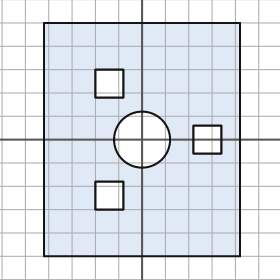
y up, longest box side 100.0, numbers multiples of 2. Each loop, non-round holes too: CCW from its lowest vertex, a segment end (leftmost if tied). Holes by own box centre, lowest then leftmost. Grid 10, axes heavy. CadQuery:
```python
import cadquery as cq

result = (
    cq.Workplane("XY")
    .moveTo(-42.0, -50.0)
    .lineTo(42.0, -50.0)
    .lineTo(42.0, 50.0)
    .lineTo(-42.0, 50.0)
    .close()
    .moveTo(-20.0, -30.0)
    .lineTo(-8.0, -30.0)
    .lineTo(-8.0, -18.0)
    .lineTo(-20.0, -18.0)
    .close()
    .moveTo(0.0, 0.0)
    .circle(12.0)
    .moveTo(22.0, -6.0)
    .lineTo(34.0, -6.0)
    .lineTo(34.0, 6.0)
    .lineTo(22.0, 6.0)
    .close()
    .moveTo(-20.0, 18.0)
    .lineTo(-8.0, 18.0)
    .lineTo(-8.0, 30.0)
    .lineTo(-20.0, 30.0)
    .close()
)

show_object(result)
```